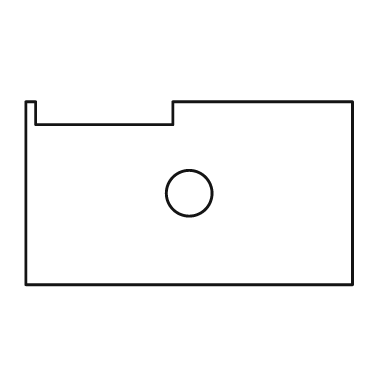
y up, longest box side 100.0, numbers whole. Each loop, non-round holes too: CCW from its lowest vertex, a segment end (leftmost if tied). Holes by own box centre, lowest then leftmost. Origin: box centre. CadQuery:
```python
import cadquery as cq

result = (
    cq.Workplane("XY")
    .moveTo(-50.0, -28.0)
    .lineTo(50.0, -28.0)
    .lineTo(50.0, 28.0)
    .lineTo(-5.0, 28.0)
    .lineTo(-5.0, 21.0)
    .lineTo(-47.0, 21.0)
    .lineTo(-47.0, 28.0)
    .lineTo(-50.0, 28.0)
    .close()
    .moveTo(0.0, 0.0)
    .circle(7.0)
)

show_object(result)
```